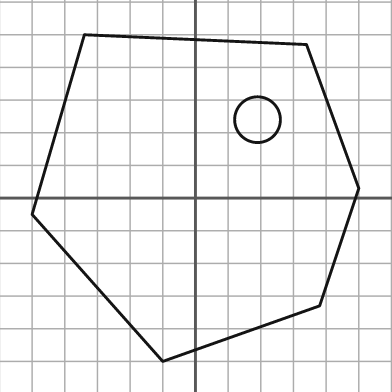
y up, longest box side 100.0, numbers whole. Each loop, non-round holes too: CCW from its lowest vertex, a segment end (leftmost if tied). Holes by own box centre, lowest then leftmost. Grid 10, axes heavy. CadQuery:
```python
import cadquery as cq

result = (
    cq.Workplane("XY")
    .moveTo(-10.0, -50.0)
    .lineTo(38.0, -33.0)
    .lineTo(50.0, 3.0)
    .lineTo(34.0, 47.0)
    .lineTo(-34.0, 50.0)
    .lineTo(-50.0, -5.0)
    .close()
    .moveTo(19.0, 24.0)
    .circle(7.0)
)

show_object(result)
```